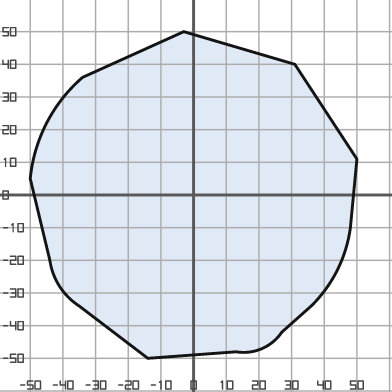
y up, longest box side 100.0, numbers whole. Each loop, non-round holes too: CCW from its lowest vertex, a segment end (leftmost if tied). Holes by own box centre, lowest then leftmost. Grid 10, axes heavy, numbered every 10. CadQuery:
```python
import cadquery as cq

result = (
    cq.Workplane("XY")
    .moveTo(-14.0, -50.0)
    .lineTo(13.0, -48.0)
    .threePointArc((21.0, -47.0), (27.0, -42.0))
    .lineTo(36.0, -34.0)
    .threePointArc((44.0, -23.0), (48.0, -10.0))
    .lineTo(50.0, 11.0)
    .lineTo(31.0, 40.0)
    .lineTo(-3.0, 50.0)
    .lineTo(-34.0, 36.0)
    .threePointArc((-45.0, 22.0), (-50.0, 5.0))
    .lineTo(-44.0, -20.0)
    .threePointArc((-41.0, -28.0), (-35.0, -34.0))
    .close()
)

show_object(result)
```